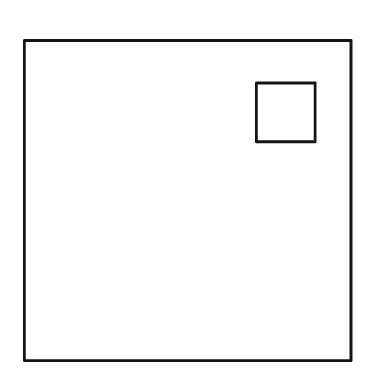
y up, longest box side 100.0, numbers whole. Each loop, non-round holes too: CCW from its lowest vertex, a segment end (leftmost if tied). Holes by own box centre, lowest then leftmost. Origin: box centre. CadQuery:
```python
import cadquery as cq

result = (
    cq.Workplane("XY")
    .moveTo(-50.0, -49.0)
    .lineTo(50.0, -49.0)
    .lineTo(50.0, 49.0)
    .lineTo(-50.0, 49.0)
    .close()
    .moveTo(21.0, 18.0)
    .lineTo(39.0, 18.0)
    .lineTo(39.0, 36.0)
    .lineTo(21.0, 36.0)
    .close()
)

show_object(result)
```